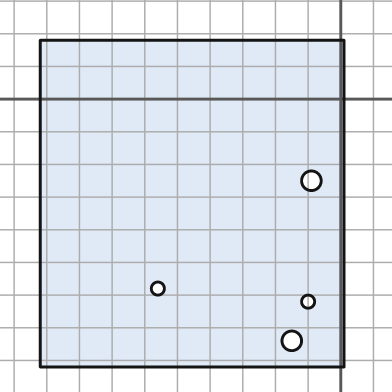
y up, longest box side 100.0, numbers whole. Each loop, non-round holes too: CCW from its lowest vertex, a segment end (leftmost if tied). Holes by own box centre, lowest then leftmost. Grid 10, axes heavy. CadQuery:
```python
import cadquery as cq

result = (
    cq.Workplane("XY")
    .moveTo(-92.0, -82.0)
    .lineTo(1.0, -82.0)
    .lineTo(1.0, 18.0)
    .lineTo(-92.0, 18.0)
    .close()
    .moveTo(-15.0, -74.0)
    .circle(3.0)
    .moveTo(-10.0, -62.0)
    .circle(2.0)
    .moveTo(-56.0, -58.0)
    .circle(2.0)
    .moveTo(-9.0, -25.0)
    .circle(3.0)
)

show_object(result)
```